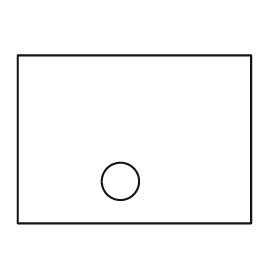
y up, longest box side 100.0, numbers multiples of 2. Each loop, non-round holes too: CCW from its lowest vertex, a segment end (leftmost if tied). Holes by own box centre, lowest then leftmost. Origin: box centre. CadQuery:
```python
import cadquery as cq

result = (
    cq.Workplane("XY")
    .moveTo(-50.0, -36.0)
    .lineTo(50.0, -36.0)
    .lineTo(50.0, 36.0)
    .lineTo(-50.0, 36.0)
    .close()
    .moveTo(-6.0, -18.0)
    .circle(8.0)
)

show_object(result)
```